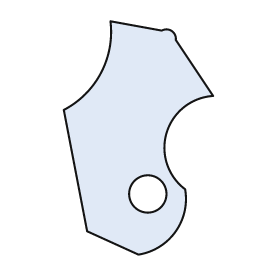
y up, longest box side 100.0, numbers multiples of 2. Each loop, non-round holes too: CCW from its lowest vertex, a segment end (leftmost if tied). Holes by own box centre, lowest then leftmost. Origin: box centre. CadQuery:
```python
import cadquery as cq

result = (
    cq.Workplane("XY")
    .moveTo(0.0, -50.0)
    .threePointArc((16.0, -40.0), (20.0, -22.0))
    .threePointArc((12.0, 2.0), (32.0, 18.0))
    .lineTo(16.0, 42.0)
    .threePointArc((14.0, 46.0), (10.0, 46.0))
    .lineTo(-12.0, 50.0)
    .threePointArc((-16.0, 28.0), (-32.0, 12.0))
    .lineTo(-22.0, -40.0)
    .close()
    .moveTo(4.0, -24.0)
    .circle(8.0)
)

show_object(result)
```